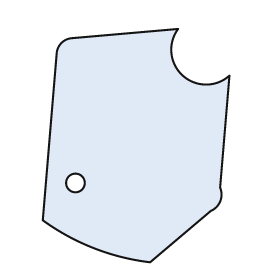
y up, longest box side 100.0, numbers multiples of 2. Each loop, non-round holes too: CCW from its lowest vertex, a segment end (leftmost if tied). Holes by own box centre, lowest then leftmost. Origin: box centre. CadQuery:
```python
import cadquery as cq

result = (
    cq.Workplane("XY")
    .moveTo(6.0, -50.0)
    .lineTo(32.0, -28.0)
    .threePointArc((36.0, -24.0), (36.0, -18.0))
    .lineTo(40.0, 30.0)
    .threePointArc((20.0, 30.0), (18.0, 50.0))
    .lineTo(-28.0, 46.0)
    .threePointArc((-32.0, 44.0), (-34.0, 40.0))
    .lineTo(-40.0, -32.0)
    .threePointArc((-18.0, -44.0), (6.0, -50.0))
    .close()
    .moveTo(-26.0, -16.0)
    .circle(4.0)
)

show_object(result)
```